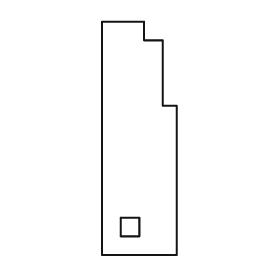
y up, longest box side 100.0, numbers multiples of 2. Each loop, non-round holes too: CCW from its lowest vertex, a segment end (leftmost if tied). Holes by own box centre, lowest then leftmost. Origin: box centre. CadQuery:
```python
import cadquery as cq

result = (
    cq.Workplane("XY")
    .moveTo(-16.0, -50.0)
    .lineTo(16.0, -50.0)
    .lineTo(16.0, 14.0)
    .lineTo(10.0, 14.0)
    .lineTo(10.0, 42.0)
    .lineTo(2.0, 42.0)
    .lineTo(2.0, 50.0)
    .lineTo(-16.0, 50.0)
    .close()
    .moveTo(-8.0, -42.0)
    .lineTo(0.0, -42.0)
    .lineTo(0.0, -34.0)
    .lineTo(-8.0, -34.0)
    .close()
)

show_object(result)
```